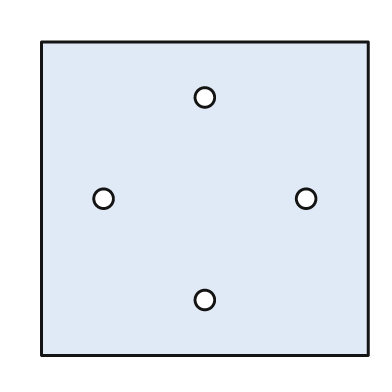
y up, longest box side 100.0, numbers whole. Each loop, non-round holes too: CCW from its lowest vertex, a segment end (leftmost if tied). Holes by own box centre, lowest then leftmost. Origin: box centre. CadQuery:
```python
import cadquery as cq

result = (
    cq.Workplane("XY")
    .moveTo(-50.0, -48.0)
    .lineTo(50.0, -48.0)
    .lineTo(50.0, 48.0)
    .lineTo(-50.0, 48.0)
    .close()
    .moveTo(0.0, -31.0)
    .circle(3.0)
    .moveTo(-31.0, 0.0)
    .circle(3.0)
    .moveTo(31.0, 0.0)
    .circle(3.0)
    .moveTo(0.0, 31.0)
    .circle(3.0)
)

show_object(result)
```